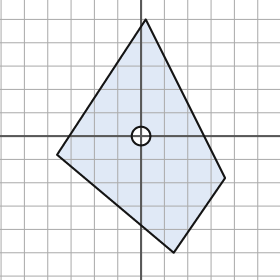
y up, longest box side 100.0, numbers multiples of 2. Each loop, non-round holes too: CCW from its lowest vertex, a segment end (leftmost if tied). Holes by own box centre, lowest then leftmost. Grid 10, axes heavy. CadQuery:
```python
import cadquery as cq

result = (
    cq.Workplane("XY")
    .moveTo(14.0, -50.0)
    .lineTo(36.0, -18.0)
    .lineTo(2.0, 50.0)
    .lineTo(-36.0, -8.0)
    .close()
    .moveTo(0.0, 0.0)
    .circle(4.0)
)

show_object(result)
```